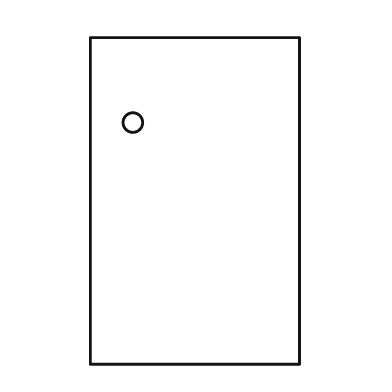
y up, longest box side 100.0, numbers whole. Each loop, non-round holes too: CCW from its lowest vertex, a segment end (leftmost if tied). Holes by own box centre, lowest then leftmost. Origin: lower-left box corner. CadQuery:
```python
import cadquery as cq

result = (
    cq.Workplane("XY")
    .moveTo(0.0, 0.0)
    .lineTo(64.0, 0.0)
    .lineTo(64.0, 100.0)
    .lineTo(0.0, 100.0)
    .close()
    .moveTo(13.0, 74.0)
    .circle(3.0)
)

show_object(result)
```